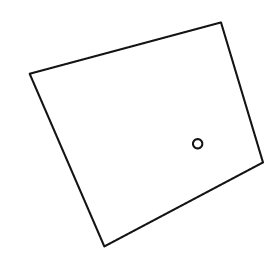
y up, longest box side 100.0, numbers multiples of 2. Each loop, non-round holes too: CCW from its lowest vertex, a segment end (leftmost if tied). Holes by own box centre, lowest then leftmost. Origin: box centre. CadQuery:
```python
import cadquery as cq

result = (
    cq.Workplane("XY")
    .moveTo(-18.0, -48.0)
    .lineTo(50.0, -12.0)
    .lineTo(32.0, 48.0)
    .lineTo(-50.0, 26.0)
    .close()
    .moveTo(22.0, -4.0)
    .circle(2.0)
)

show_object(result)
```